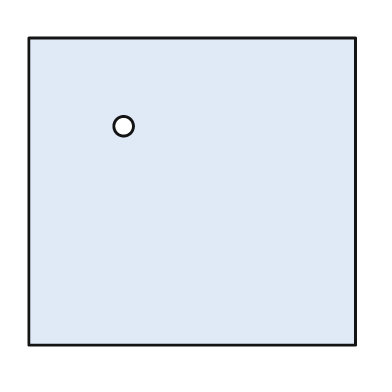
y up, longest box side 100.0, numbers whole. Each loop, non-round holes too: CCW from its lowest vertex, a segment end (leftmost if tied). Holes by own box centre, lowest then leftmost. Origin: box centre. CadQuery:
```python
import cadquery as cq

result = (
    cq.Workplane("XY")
    .moveTo(-50.0, -47.0)
    .lineTo(50.0, -47.0)
    .lineTo(50.0, 47.0)
    .lineTo(-50.0, 47.0)
    .close()
    .moveTo(-21.0, 20.0)
    .circle(3.0)
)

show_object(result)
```